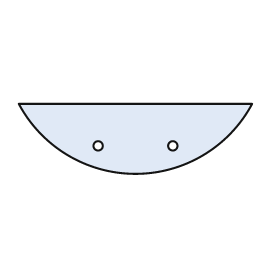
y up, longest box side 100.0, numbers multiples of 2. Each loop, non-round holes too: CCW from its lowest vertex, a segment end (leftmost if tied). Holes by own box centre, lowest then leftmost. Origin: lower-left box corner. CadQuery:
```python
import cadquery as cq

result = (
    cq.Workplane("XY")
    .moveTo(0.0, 30.0)
    .threePointArc((50.0, 0.0), (100.0, 30.0))
    .close()
    .moveTo(34.0, 12.0)
    .circle(2.0)
    .moveTo(66.0, 12.0)
    .circle(2.0)
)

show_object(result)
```